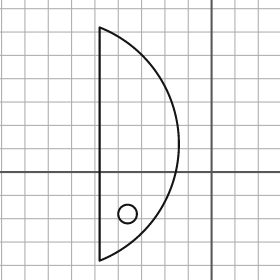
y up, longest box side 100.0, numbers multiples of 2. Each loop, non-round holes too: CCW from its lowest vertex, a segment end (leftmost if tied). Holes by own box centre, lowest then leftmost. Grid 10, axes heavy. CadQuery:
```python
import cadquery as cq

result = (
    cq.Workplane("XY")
    .moveTo(-48.0, -38.0)
    .threePointArc((-14.0, 12.0), (-48.0, 62.0))
    .close()
    .moveTo(-36.0, -18.0)
    .circle(4.0)
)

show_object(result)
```